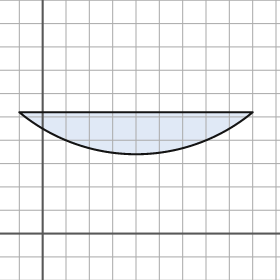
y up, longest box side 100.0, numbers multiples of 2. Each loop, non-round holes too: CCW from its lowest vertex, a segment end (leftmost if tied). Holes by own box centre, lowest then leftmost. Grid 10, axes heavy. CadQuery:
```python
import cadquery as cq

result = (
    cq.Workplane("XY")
    .moveTo(-10.0, 52.0)
    .threePointArc((40.0, 34.0), (90.0, 52.0))
    .close()
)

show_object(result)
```